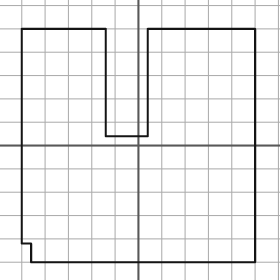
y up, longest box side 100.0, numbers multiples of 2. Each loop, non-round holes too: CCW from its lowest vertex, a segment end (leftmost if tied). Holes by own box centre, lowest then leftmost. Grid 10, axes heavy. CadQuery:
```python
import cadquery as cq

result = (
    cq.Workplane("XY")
    .moveTo(-46.0, -50.0)
    .lineTo(50.0, -50.0)
    .lineTo(50.0, 50.0)
    .lineTo(4.0, 50.0)
    .lineTo(4.0, 4.0)
    .lineTo(-14.0, 4.0)
    .lineTo(-14.0, 50.0)
    .lineTo(-50.0, 50.0)
    .lineTo(-50.0, -42.0)
    .lineTo(-46.0, -42.0)
    .close()
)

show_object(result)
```